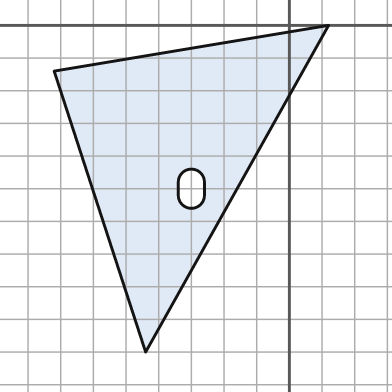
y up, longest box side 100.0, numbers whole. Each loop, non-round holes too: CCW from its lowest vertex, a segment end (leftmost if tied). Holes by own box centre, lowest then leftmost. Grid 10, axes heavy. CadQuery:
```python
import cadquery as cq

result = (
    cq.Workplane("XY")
    .moveTo(-44.0, -100.0)
    .lineTo(12.0, 0.0)
    .lineTo(-72.0, -14.0)
    .close()
    .moveTo(-34.0, -52.0)
    .threePointArc((-30.0, -56.0), (-26.0, -52.0))
    .lineTo(-26.0, -48.0)
    .threePointArc((-30.0, -44.0), (-34.0, -48.0))
    .close()
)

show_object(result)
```